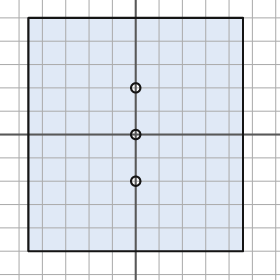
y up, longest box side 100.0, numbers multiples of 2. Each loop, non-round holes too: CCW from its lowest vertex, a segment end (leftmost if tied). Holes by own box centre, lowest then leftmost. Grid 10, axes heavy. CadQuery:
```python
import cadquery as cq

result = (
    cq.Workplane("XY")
    .moveTo(-46.0, -50.0)
    .lineTo(46.0, -50.0)
    .lineTo(46.0, 50.0)
    .lineTo(-46.0, 50.0)
    .close()
    .moveTo(0.0, -20.0)
    .circle(2.0)
    .moveTo(0.0, 0.0)
    .circle(2.0)
    .moveTo(0.0, 20.0)
    .circle(2.0)
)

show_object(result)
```